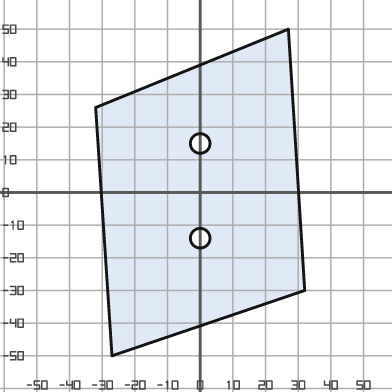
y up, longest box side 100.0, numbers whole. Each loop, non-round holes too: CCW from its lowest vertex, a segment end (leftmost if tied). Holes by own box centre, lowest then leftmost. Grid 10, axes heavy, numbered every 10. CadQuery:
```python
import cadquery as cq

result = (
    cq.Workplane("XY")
    .moveTo(-27.0, -50.0)
    .lineTo(32.0, -30.0)
    .lineTo(27.0, 50.0)
    .lineTo(-32.0, 26.0)
    .close()
    .moveTo(0.0, -14.0)
    .circle(3.0)
    .moveTo(0.0, 15.0)
    .circle(3.0)
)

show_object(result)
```